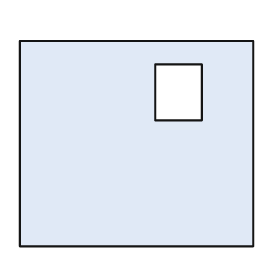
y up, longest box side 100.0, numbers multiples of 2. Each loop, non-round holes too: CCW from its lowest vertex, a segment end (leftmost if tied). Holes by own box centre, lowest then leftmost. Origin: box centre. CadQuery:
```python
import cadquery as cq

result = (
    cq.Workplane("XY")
    .moveTo(-50.0, -44.0)
    .lineTo(50.0, -44.0)
    .lineTo(50.0, 44.0)
    .lineTo(-50.0, 44.0)
    .close()
    .moveTo(8.0, 10.0)
    .lineTo(28.0, 10.0)
    .lineTo(28.0, 34.0)
    .lineTo(8.0, 34.0)
    .close()
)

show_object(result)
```